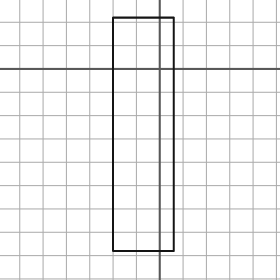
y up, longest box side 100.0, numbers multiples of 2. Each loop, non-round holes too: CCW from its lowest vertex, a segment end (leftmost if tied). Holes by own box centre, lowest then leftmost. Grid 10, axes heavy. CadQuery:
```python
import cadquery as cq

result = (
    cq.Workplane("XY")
    .moveTo(-20.0, -78.0)
    .lineTo(6.0, -78.0)
    .lineTo(6.0, 22.0)
    .lineTo(-20.0, 22.0)
    .close()
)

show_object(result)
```